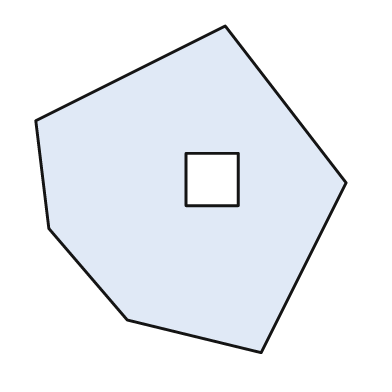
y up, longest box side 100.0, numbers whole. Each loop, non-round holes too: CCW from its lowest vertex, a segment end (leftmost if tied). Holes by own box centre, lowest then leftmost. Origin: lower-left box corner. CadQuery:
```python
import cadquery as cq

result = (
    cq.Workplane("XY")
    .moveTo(69.0, 0.0)
    .lineTo(95.0, 52.0)
    .lineTo(58.0, 100.0)
    .lineTo(0.0, 71.0)
    .lineTo(4.0, 38.0)
    .lineTo(28.0, 10.0)
    .close()
    .moveTo(46.0, 45.0)
    .lineTo(62.0, 45.0)
    .lineTo(62.0, 61.0)
    .lineTo(46.0, 61.0)
    .close()
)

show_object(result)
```